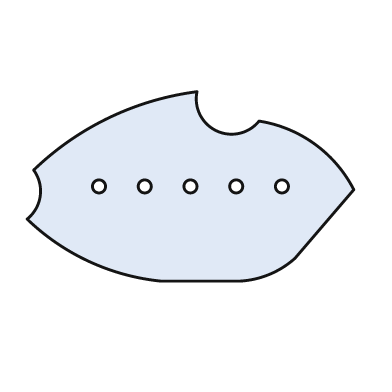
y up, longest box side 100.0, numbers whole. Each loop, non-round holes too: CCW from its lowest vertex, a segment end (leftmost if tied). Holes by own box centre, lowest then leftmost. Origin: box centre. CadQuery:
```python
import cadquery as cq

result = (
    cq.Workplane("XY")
    .moveTo(-9.0, -29.0)
    .lineTo(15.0, -29.0)
    .threePointArc((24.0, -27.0), (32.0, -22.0))
    .lineTo(50.0, -1.0)
    .threePointArc((38.0, 13.0), (21.0, 20.0))
    .threePointArc((8.0, 17.0), (2.0, 29.0))
    .threePointArc((-25.0, 21.0), (-48.0, 5.0))
    .threePointArc((-46.0, -3.0), (-50.0, -10.0))
    .threePointArc((-31.0, -23.0), (-9.0, -29.0))
    .close()
    .moveTo(-28.0, 0.0)
    .circle(2.0)
    .moveTo(-14.0, 0.0)
    .circle(2.0)
    .moveTo(0.0, 0.0)
    .circle(2.0)
    .moveTo(14.0, 0.0)
    .circle(2.0)
    .moveTo(28.0, 0.0)
    .circle(2.0)
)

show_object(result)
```